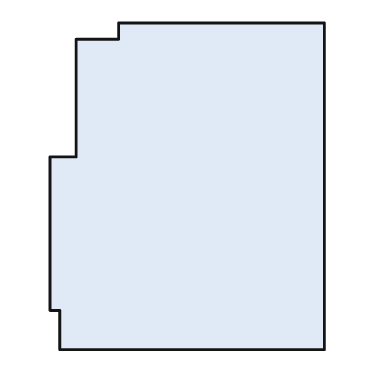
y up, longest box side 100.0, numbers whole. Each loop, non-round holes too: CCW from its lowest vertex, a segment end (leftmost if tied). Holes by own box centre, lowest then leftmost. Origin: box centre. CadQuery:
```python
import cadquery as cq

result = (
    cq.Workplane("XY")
    .moveTo(-39.0, -50.0)
    .lineTo(42.0, -50.0)
    .lineTo(42.0, 50.0)
    .lineTo(-21.0, 50.0)
    .lineTo(-21.0, 45.0)
    .lineTo(-34.0, 45.0)
    .lineTo(-34.0, 9.0)
    .lineTo(-42.0, 9.0)
    .lineTo(-42.0, -38.0)
    .lineTo(-39.0, -38.0)
    .close()
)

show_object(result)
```